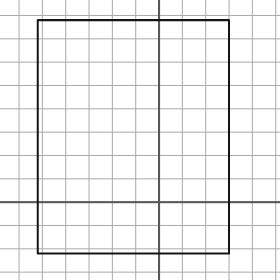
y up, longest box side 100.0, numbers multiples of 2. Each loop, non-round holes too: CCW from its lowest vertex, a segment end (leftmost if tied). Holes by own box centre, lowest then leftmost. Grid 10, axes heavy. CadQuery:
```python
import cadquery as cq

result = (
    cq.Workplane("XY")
    .moveTo(-52.0, -22.0)
    .lineTo(30.0, -22.0)
    .lineTo(30.0, 78.0)
    .lineTo(-52.0, 78.0)
    .close()
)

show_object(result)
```